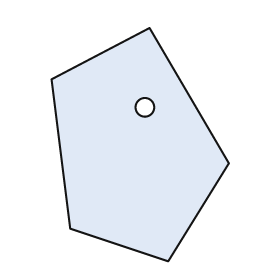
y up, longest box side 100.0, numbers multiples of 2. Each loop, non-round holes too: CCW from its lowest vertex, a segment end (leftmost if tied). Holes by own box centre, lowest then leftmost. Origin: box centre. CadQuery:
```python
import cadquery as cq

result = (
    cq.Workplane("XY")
    .moveTo(12.0, -50.0)
    .lineTo(38.0, -8.0)
    .lineTo(4.0, 50.0)
    .lineTo(-38.0, 28.0)
    .lineTo(-30.0, -36.0)
    .close()
    .moveTo(2.0, 16.0)
    .circle(4.0)
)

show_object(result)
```